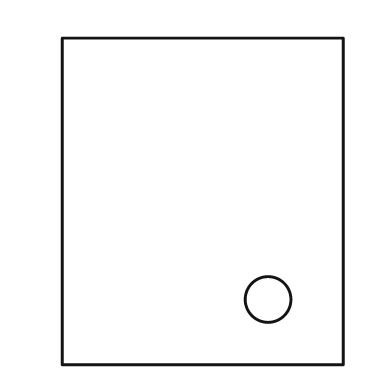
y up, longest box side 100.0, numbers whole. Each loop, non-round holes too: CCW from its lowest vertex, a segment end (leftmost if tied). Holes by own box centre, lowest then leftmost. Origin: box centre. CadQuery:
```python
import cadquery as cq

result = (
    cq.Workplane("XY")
    .moveTo(-43.0, -50.0)
    .lineTo(43.0, -50.0)
    .lineTo(43.0, 50.0)
    .lineTo(-43.0, 50.0)
    .close()
    .moveTo(20.0, -30.0)
    .circle(7.0)
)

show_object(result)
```